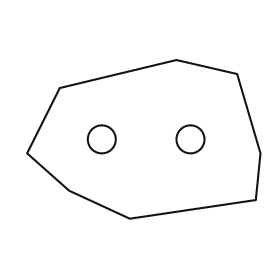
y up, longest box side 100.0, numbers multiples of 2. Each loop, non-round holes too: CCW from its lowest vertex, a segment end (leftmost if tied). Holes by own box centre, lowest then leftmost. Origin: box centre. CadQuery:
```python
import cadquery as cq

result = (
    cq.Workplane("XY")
    .moveTo(-6.0, -34.0)
    .lineTo(48.0, -26.0)
    .lineTo(50.0, -6.0)
    .lineTo(40.0, 28.0)
    .lineTo(14.0, 34.0)
    .lineTo(-36.0, 22.0)
    .lineTo(-50.0, -6.0)
    .lineTo(-32.0, -22.0)
    .close()
    .moveTo(-18.0, 0.0)
    .circle(6.0)
    .moveTo(20.0, 0.0)
    .circle(6.0)
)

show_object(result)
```